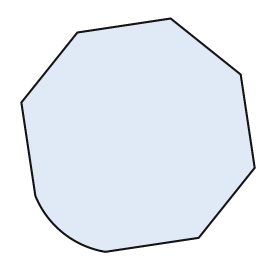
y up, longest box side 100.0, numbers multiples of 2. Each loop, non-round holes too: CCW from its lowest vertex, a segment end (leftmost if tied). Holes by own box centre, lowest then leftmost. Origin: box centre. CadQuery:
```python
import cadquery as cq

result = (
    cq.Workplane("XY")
    .moveTo(-14.0, -50.0)
    .lineTo(26.0, -44.0)
    .lineTo(50.0, -14.0)
    .lineTo(44.0, 26.0)
    .lineTo(14.0, 50.0)
    .lineTo(-26.0, 44.0)
    .lineTo(-50.0, 14.0)
    .lineTo(-44.0, -26.0)
    .threePointArc((-32.0, -42.0), (-14.0, -50.0))
    .close()
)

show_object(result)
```